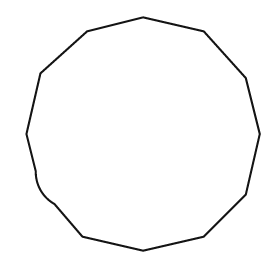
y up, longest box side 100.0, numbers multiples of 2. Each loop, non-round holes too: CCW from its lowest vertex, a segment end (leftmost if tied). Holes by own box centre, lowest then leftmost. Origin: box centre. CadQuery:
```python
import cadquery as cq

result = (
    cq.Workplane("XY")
    .moveTo(0.0, -50.0)
    .lineTo(26.0, -44.0)
    .lineTo(44.0, -26.0)
    .lineTo(50.0, 0.0)
    .lineTo(44.0, 24.0)
    .lineTo(26.0, 44.0)
    .lineTo(0.0, 50.0)
    .lineTo(-24.0, 44.0)
    .lineTo(-44.0, 26.0)
    .lineTo(-50.0, 0.0)
    .lineTo(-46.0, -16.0)
    .threePointArc((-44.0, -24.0), (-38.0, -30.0))
    .lineTo(-26.0, -44.0)
    .close()
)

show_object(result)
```